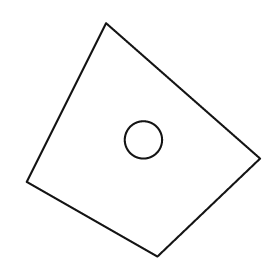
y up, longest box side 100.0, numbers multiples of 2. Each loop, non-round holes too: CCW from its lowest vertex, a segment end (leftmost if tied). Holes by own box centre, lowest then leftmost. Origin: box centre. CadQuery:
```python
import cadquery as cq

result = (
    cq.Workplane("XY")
    .moveTo(6.0, -50.0)
    .lineTo(50.0, -8.0)
    .lineTo(-16.0, 50.0)
    .lineTo(-50.0, -18.0)
    .close()
    .moveTo(0.0, 0.0)
    .circle(8.0)
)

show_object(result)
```